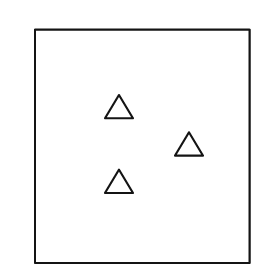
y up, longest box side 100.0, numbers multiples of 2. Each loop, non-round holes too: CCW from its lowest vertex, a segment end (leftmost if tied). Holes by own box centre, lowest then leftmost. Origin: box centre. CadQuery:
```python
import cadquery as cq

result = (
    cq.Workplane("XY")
    .moveTo(-46.0, -50.0)
    .lineTo(46.0, -50.0)
    .lineTo(46.0, 50.0)
    .lineTo(-46.0, 50.0)
    .close()
    .moveTo(-16.0, -20.0)
    .lineTo(-4.0, -20.0)
    .lineTo(-10.0, -10.0)
    .close()
    .moveTo(14.0, -4.0)
    .lineTo(26.0, -4.0)
    .lineTo(20.0, 6.0)
    .close()
    .moveTo(-16.0, 12.0)
    .lineTo(-4.0, 12.0)
    .lineTo(-10.0, 22.0)
    .close()
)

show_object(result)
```